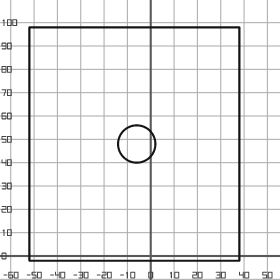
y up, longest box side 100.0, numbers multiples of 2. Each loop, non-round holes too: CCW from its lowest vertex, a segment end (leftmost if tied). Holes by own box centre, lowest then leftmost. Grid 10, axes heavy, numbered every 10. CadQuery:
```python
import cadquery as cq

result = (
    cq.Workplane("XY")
    .moveTo(-52.0, -2.0)
    .lineTo(38.0, -2.0)
    .lineTo(38.0, 98.0)
    .lineTo(-52.0, 98.0)
    .close()
    .moveTo(-6.0, 48.0)
    .circle(8.0)
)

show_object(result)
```